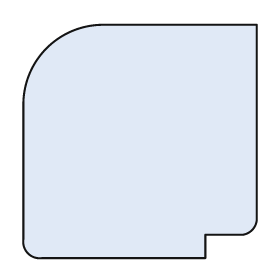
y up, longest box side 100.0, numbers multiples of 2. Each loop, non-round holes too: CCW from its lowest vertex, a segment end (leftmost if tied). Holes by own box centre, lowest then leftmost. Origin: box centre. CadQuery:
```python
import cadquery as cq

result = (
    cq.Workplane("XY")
    .moveTo(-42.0, -50.0)
    .lineTo(28.0, -50.0)
    .lineTo(28.0, -40.0)
    .lineTo(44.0, -40.0)
    .threePointArc((48.0, -38.0), (50.0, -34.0))
    .lineTo(50.0, 50.0)
    .lineTo(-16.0, 50.0)
    .threePointArc((-40.0, 40.0), (-50.0, 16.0))
    .lineTo(-50.0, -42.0)
    .threePointArc((-48.0, -48.0), (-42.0, -50.0))
    .close()
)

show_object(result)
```